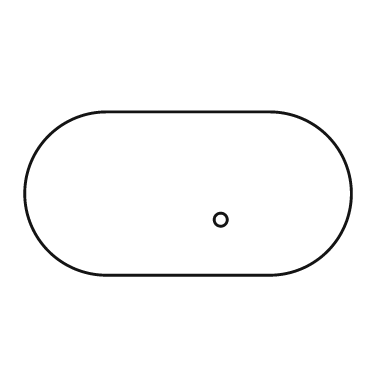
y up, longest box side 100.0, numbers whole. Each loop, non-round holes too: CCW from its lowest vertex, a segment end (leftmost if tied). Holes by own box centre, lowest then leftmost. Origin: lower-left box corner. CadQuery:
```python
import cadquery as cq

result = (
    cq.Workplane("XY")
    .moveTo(25.0, 0.0)
    .lineTo(75.0, 0.0)
    .threePointArc((100.0, 25.0), (75.0, 50.0))
    .lineTo(25.0, 50.0)
    .threePointArc((0.0, 25.0), (25.0, 0.0))
    .close()
    .moveTo(60.0, 17.0)
    .circle(2.0)
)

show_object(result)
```